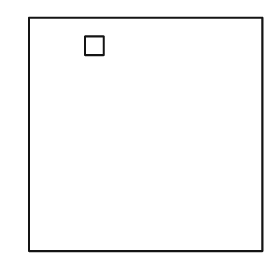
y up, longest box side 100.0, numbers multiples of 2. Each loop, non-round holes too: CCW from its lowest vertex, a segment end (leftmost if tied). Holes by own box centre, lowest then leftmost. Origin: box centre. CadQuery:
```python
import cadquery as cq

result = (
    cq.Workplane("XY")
    .moveTo(-50.0, -50.0)
    .lineTo(50.0, -50.0)
    .lineTo(50.0, 50.0)
    .lineTo(-50.0, 50.0)
    .close()
    .moveTo(-26.0, 34.0)
    .lineTo(-18.0, 34.0)
    .lineTo(-18.0, 42.0)
    .lineTo(-26.0, 42.0)
    .close()
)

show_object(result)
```